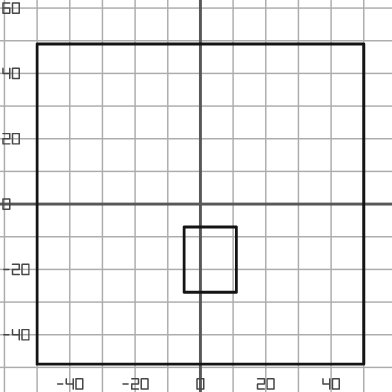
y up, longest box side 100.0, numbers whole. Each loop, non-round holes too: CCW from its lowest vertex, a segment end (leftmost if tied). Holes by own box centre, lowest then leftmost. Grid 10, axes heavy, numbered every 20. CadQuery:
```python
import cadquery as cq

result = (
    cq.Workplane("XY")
    .moveTo(-50.0, -49.0)
    .lineTo(50.0, -49.0)
    .lineTo(50.0, 49.0)
    .lineTo(-50.0, 49.0)
    .close()
    .moveTo(-5.0, -27.0)
    .lineTo(11.0, -27.0)
    .lineTo(11.0, -7.0)
    .lineTo(-5.0, -7.0)
    .close()
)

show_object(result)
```